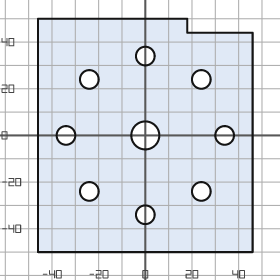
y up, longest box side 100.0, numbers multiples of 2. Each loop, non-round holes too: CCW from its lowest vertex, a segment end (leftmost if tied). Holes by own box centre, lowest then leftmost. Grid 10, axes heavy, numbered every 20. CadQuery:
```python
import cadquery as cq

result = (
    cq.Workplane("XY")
    .moveTo(-46.0, -50.0)
    .lineTo(46.0, -50.0)
    .lineTo(46.0, 44.0)
    .lineTo(18.0, 44.0)
    .lineTo(18.0, 50.0)
    .lineTo(-46.0, 50.0)
    .close()
    .moveTo(0.0, -34.0)
    .circle(4.0)
    .moveTo(-24.0, -24.0)
    .circle(4.0)
    .moveTo(24.0, -24.0)
    .circle(4.0)
    .moveTo(-34.0, 0.0)
    .circle(4.0)
    .moveTo(0.0, 0.0)
    .circle(6.0)
    .moveTo(34.0, 0.0)
    .circle(4.0)
    .moveTo(-24.0, 24.0)
    .circle(4.0)
    .moveTo(24.0, 24.0)
    .circle(4.0)
    .moveTo(0.0, 34.0)
    .circle(4.0)
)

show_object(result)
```